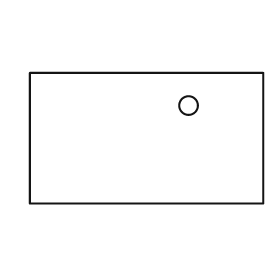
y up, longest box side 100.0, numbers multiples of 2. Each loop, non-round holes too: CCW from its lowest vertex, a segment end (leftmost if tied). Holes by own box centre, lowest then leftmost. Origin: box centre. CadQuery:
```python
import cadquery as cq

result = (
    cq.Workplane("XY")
    .moveTo(-50.0, -28.0)
    .lineTo(50.0, -28.0)
    .lineTo(50.0, 28.0)
    .lineTo(-50.0, 28.0)
    .close()
    .moveTo(18.0, 14.0)
    .circle(4.0)
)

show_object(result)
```